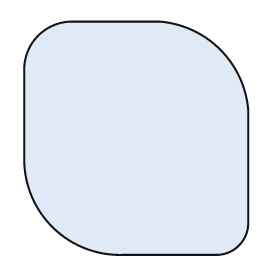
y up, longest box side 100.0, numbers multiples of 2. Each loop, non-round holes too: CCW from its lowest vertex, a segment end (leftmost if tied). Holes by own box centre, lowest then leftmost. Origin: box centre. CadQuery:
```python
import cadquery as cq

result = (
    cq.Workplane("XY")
    .moveTo(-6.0, -50.0)
    .lineTo(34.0, -50.0)
    .threePointArc((44.0, -46.0), (48.0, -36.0))
    .lineTo(48.0, 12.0)
    .threePointArc((36.0, 38.0), (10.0, 50.0))
    .lineTo(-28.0, 50.0)
    .threePointArc((-42.0, 44.0), (-48.0, 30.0))
    .lineTo(-48.0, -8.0)
    .threePointArc((-36.0, -38.0), (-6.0, -50.0))
    .close()
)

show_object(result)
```